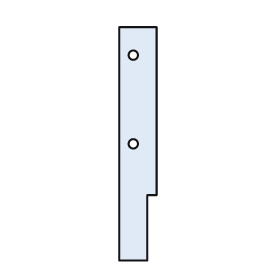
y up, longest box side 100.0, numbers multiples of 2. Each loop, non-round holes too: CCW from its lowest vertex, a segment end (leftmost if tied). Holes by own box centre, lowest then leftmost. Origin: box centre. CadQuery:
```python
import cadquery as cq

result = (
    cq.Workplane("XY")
    .moveTo(-8.0, -50.0)
    .lineTo(4.0, -50.0)
    .lineTo(4.0, -22.0)
    .lineTo(8.0, -22.0)
    .lineTo(8.0, 50.0)
    .lineTo(-8.0, 50.0)
    .close()
    .moveTo(-2.0, 0.0)
    .circle(2.0)
    .moveTo(-2.0, 38.0)
    .circle(2.0)
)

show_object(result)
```